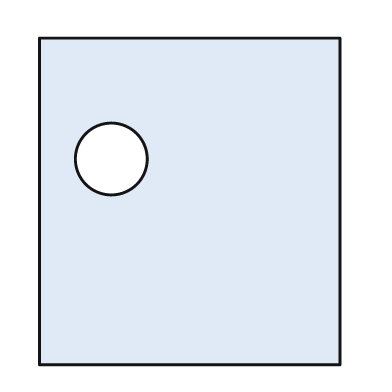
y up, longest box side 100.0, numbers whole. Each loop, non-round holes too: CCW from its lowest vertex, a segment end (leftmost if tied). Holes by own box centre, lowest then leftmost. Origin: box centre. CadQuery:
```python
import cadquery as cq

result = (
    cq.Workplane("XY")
    .moveTo(-46.0, -50.0)
    .lineTo(46.0, -50.0)
    .lineTo(46.0, 50.0)
    .lineTo(-46.0, 50.0)
    .close()
    .moveTo(-24.0, 13.0)
    .circle(11.0)
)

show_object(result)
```